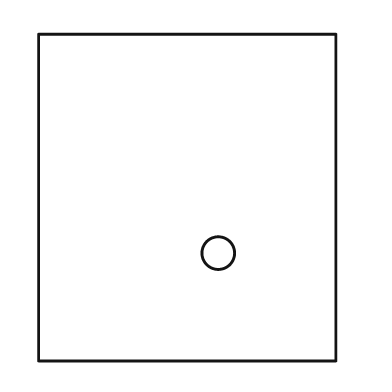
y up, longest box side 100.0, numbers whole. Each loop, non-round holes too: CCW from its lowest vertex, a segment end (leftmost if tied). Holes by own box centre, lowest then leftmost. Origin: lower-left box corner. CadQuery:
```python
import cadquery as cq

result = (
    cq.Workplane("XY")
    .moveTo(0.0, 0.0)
    .lineTo(91.0, 0.0)
    .lineTo(91.0, 100.0)
    .lineTo(0.0, 100.0)
    .close()
    .moveTo(55.0, 33.0)
    .circle(5.0)
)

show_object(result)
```